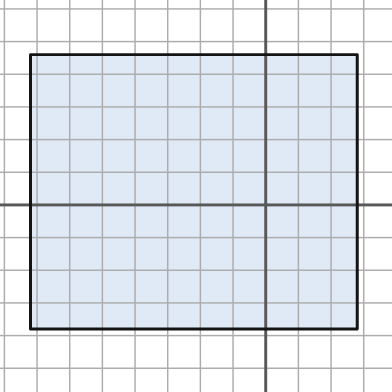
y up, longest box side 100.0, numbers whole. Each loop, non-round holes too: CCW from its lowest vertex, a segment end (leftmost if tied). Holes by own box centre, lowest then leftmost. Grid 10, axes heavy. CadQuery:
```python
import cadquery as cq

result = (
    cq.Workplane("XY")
    .moveTo(-72.0, -38.0)
    .lineTo(28.0, -38.0)
    .lineTo(28.0, 46.0)
    .lineTo(-72.0, 46.0)
    .close()
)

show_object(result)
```